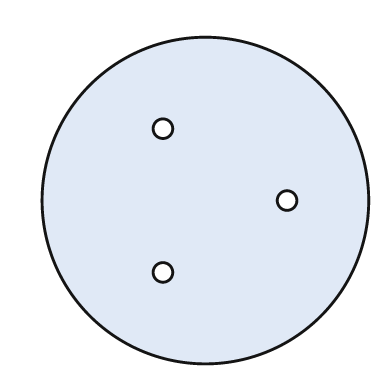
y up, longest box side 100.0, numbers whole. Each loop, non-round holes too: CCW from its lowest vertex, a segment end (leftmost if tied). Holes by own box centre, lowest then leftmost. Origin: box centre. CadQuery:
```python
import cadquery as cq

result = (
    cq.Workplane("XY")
    .moveTo(0.0, 0.0)
    .circle(50.0)
    .moveTo(-13.0, -22.0)
    .circle(3.0)
    .moveTo(25.0, 0.0)
    .circle(3.0)
    .moveTo(-13.0, 22.0)
    .circle(3.0)
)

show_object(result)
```